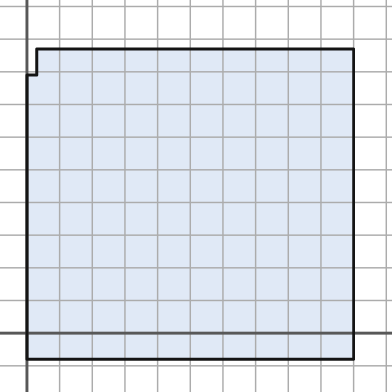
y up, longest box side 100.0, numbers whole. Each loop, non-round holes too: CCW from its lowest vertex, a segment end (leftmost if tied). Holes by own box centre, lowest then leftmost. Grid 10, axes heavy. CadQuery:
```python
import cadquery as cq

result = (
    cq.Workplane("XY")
    .moveTo(0.0, -8.0)
    .lineTo(100.0, -8.0)
    .lineTo(100.0, 87.0)
    .lineTo(3.0, 87.0)
    .lineTo(3.0, 79.0)
    .lineTo(0.0, 79.0)
    .close()
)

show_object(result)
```